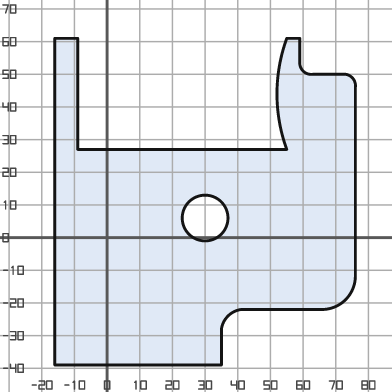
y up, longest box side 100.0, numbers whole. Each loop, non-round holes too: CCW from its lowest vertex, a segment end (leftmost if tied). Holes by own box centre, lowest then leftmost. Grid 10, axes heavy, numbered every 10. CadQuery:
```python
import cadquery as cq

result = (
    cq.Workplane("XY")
    .moveTo(-16.0, -39.0)
    .lineTo(35.0, -39.0)
    .lineTo(35.0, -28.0)
    .threePointArc((37.0, -24.0), (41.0, -22.0))
    .lineTo(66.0, -22.0)
    .threePointArc((73.0, -19.0), (76.0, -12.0))
    .lineTo(76.0, 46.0)
    .threePointArc((75.0, 49.0), (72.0, 50.0))
    .lineTo(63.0, 50.0)
    .threePointArc((60.0, 51.0), (59.0, 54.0))
    .lineTo(59.0, 61.0)
    .lineTo(55.0, 61.0)
    .threePointArc((52.0, 44.0), (55.0, 27.0))
    .lineTo(-9.0, 27.0)
    .lineTo(-9.0, 61.0)
    .lineTo(-16.0, 61.0)
    .close()
    .moveTo(30.0, 6.0)
    .circle(7.0)
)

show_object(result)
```